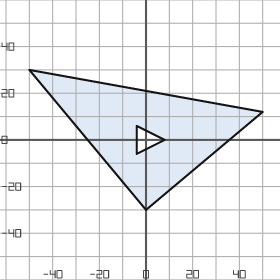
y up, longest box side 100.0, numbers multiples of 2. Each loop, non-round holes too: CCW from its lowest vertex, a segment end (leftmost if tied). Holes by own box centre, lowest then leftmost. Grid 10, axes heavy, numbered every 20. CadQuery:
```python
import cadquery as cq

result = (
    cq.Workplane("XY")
    .moveTo(0.0, -30.0)
    .lineTo(50.0, 12.0)
    .lineTo(-50.0, 30.0)
    .close()
    .moveTo(-4.0, -6.0)
    .lineTo(8.0, 0.0)
    .lineTo(-4.0, 6.0)
    .close()
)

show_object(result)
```